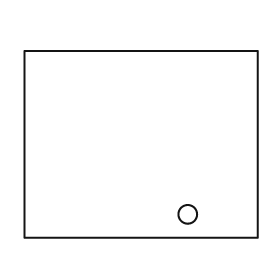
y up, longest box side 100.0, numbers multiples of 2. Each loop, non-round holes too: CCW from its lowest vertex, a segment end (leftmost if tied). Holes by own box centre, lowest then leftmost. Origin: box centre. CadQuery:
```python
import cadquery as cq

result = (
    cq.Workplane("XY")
    .moveTo(-50.0, -40.0)
    .lineTo(50.0, -40.0)
    .lineTo(50.0, 40.0)
    .lineTo(-50.0, 40.0)
    .close()
    .moveTo(20.0, -30.0)
    .circle(4.0)
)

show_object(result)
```